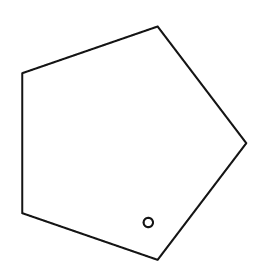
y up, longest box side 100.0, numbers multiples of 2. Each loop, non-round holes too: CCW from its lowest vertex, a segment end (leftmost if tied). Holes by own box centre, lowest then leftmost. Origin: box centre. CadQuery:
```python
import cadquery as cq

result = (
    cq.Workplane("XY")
    .moveTo(10.0, -50.0)
    .lineTo(48.0, 0.0)
    .lineTo(10.0, 50.0)
    .lineTo(-48.0, 30.0)
    .lineTo(-48.0, -30.0)
    .close()
    .moveTo(6.0, -34.0)
    .circle(2.0)
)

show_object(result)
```